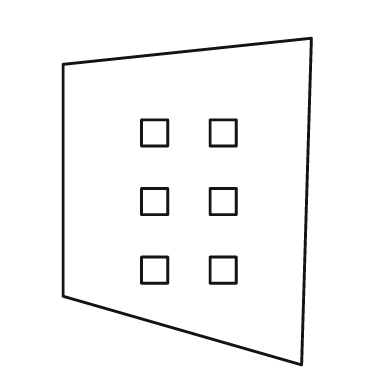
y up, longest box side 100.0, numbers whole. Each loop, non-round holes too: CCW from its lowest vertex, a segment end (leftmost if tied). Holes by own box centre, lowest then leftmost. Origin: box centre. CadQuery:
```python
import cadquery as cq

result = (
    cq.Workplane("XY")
    .moveTo(35.0, -50.0)
    .lineTo(38.0, 50.0)
    .lineTo(-38.0, 42.0)
    .lineTo(-38.0, -29.0)
    .close()
    .moveTo(-14.0, -25.0)
    .lineTo(-6.0, -25.0)
    .lineTo(-6.0, -17.0)
    .lineTo(-14.0, -17.0)
    .close()
    .moveTo(7.0, -25.0)
    .lineTo(15.0, -25.0)
    .lineTo(15.0, -17.0)
    .lineTo(7.0, -17.0)
    .close()
    .moveTo(-14.0, -4.0)
    .lineTo(-6.0, -4.0)
    .lineTo(-6.0, 4.0)
    .lineTo(-14.0, 4.0)
    .close()
    .moveTo(7.0, -4.0)
    .lineTo(15.0, -4.0)
    .lineTo(15.0, 4.0)
    .lineTo(7.0, 4.0)
    .close()
    .moveTo(-14.0, 17.0)
    .lineTo(-6.0, 17.0)
    .lineTo(-6.0, 25.0)
    .lineTo(-14.0, 25.0)
    .close()
    .moveTo(7.0, 17.0)
    .lineTo(15.0, 17.0)
    .lineTo(15.0, 25.0)
    .lineTo(7.0, 25.0)
    .close()
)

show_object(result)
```